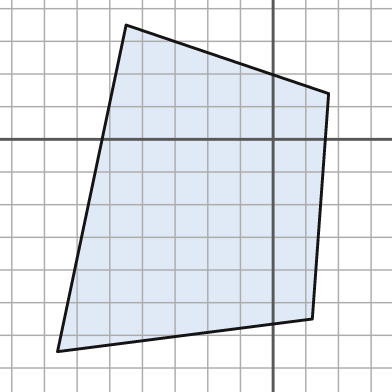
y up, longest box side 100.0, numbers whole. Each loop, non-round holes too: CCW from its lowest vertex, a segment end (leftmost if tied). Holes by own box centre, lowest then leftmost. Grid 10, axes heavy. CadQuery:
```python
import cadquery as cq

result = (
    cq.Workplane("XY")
    .moveTo(-66.0, -65.0)
    .lineTo(12.0, -55.0)
    .lineTo(17.0, 14.0)
    .lineTo(-45.0, 35.0)
    .close()
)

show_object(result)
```